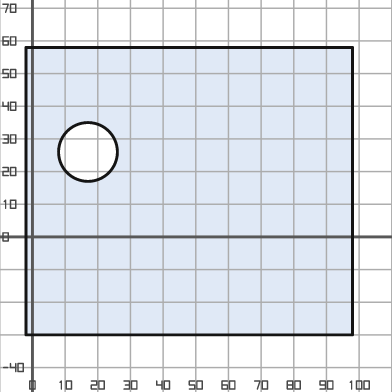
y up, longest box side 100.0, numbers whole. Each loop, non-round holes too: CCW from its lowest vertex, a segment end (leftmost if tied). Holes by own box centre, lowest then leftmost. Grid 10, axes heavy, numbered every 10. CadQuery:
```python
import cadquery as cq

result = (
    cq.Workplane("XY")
    .moveTo(-2.0, -30.0)
    .lineTo(98.0, -30.0)
    .lineTo(98.0, 58.0)
    .lineTo(-2.0, 58.0)
    .close()
    .moveTo(17.0, 26.0)
    .circle(9.0)
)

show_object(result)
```